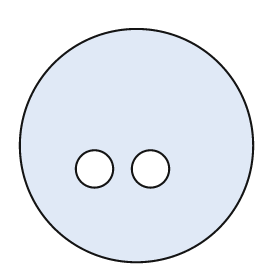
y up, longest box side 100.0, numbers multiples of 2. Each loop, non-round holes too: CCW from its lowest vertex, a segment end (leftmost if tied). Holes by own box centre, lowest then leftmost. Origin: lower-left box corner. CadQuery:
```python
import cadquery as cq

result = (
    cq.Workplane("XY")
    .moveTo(50.0, 50.0)
    .circle(50.0)
    .moveTo(32.0, 40.0)
    .circle(8.0)
    .moveTo(56.0, 40.0)
    .circle(8.0)
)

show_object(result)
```